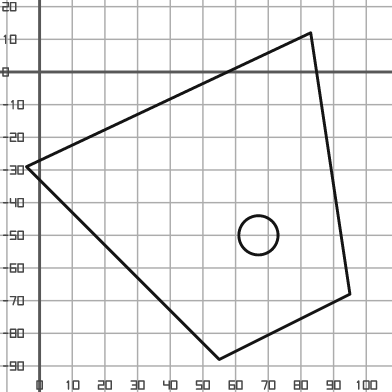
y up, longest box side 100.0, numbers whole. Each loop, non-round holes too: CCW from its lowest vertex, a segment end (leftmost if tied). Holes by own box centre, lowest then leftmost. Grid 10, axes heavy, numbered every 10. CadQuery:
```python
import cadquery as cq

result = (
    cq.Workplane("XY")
    .moveTo(55.0, -88.0)
    .lineTo(95.0, -68.0)
    .lineTo(83.0, 12.0)
    .lineTo(-4.0, -29.0)
    .close()
    .moveTo(67.0, -50.0)
    .circle(6.0)
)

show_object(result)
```